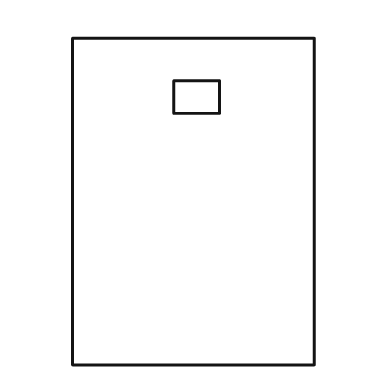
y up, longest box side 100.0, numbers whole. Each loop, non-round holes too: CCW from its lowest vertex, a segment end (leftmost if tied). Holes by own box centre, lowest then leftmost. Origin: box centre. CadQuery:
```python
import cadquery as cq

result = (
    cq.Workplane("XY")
    .moveTo(-37.0, -50.0)
    .lineTo(37.0, -50.0)
    .lineTo(37.0, 50.0)
    .lineTo(-37.0, 50.0)
    .close()
    .moveTo(-6.0, 27.0)
    .lineTo(8.0, 27.0)
    .lineTo(8.0, 37.0)
    .lineTo(-6.0, 37.0)
    .close()
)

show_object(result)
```